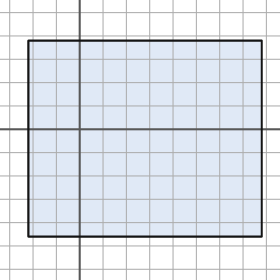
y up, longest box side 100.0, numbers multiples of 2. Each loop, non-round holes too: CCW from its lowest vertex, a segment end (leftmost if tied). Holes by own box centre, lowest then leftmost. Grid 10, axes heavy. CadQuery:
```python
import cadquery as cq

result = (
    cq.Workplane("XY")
    .moveTo(-22.0, -46.0)
    .lineTo(78.0, -46.0)
    .lineTo(78.0, 38.0)
    .lineTo(-22.0, 38.0)
    .close()
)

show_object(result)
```